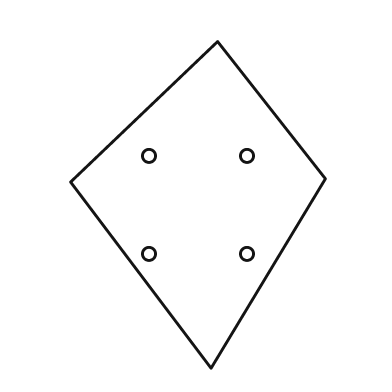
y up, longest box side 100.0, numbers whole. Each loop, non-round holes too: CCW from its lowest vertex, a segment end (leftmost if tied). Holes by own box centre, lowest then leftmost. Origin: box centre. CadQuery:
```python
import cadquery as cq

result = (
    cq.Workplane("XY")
    .moveTo(4.0, -50.0)
    .lineTo(39.0, 8.0)
    .lineTo(6.0, 50.0)
    .lineTo(-39.0, 7.0)
    .close()
    .moveTo(-15.0, -15.0)
    .circle(2.0)
    .moveTo(15.0, -15.0)
    .circle(2.0)
    .moveTo(-15.0, 15.0)
    .circle(2.0)
    .moveTo(15.0, 15.0)
    .circle(2.0)
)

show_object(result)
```